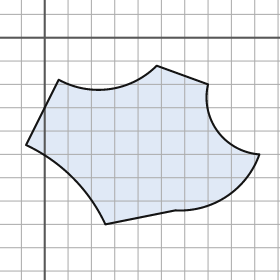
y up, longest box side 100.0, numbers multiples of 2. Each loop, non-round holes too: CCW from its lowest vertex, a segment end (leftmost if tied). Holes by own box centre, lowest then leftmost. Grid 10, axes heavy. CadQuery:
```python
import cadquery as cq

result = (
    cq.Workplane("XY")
    .moveTo(26.0, -80.0)
    .lineTo(56.0, -74.0)
    .threePointArc((78.0, -68.0), (92.0, -50.0))
    .threePointArc((74.0, -40.0), (70.0, -20.0))
    .lineTo(48.0, -12.0)
    .threePointArc((28.0, -22.0), (6.0, -18.0))
    .lineTo(-8.0, -46.0)
    .threePointArc((12.0, -60.0), (26.0, -80.0))
    .close()
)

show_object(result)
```